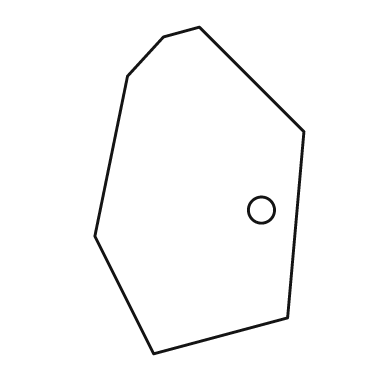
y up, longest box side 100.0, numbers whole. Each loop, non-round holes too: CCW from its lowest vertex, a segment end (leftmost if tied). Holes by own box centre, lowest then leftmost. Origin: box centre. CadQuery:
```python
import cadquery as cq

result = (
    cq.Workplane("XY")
    .moveTo(-14.0, -50.0)
    .lineTo(27.0, -39.0)
    .lineTo(32.0, 18.0)
    .lineTo(0.0, 50.0)
    .lineTo(-11.0, 47.0)
    .lineTo(-22.0, 35.0)
    .lineTo(-32.0, -14.0)
    .close()
    .moveTo(19.0, -6.0)
    .circle(4.0)
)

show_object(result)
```